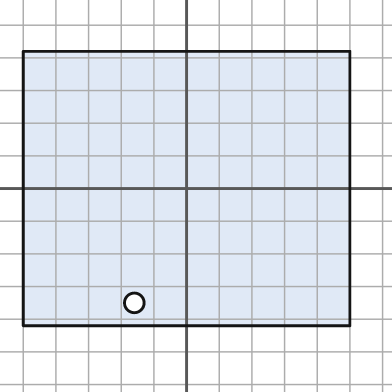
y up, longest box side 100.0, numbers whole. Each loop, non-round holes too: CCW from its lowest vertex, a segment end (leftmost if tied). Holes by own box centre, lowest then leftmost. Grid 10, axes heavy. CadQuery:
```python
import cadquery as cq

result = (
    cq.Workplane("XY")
    .moveTo(-50.0, -42.0)
    .lineTo(50.0, -42.0)
    .lineTo(50.0, 42.0)
    .lineTo(-50.0, 42.0)
    .close()
    .moveTo(-16.0, -35.0)
    .circle(3.0)
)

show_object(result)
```